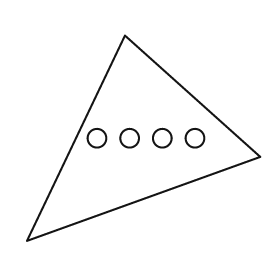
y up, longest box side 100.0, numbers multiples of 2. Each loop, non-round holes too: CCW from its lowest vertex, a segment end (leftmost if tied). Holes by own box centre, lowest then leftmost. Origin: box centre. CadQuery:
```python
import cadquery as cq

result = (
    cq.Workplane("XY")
    .moveTo(-50.0, -44.0)
    .lineTo(50.0, -8.0)
    .lineTo(-8.0, 44.0)
    .close()
    .moveTo(-20.0, 0.0)
    .circle(4.0)
    .moveTo(-6.0, 0.0)
    .circle(4.0)
    .moveTo(8.0, 0.0)
    .circle(4.0)
    .moveTo(22.0, 0.0)
    .circle(4.0)
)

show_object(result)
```